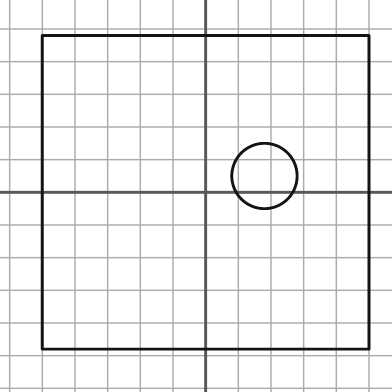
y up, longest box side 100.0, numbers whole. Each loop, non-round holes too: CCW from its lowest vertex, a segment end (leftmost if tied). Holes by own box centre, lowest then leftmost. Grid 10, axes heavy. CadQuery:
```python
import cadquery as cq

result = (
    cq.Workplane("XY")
    .moveTo(-50.0, -48.0)
    .lineTo(50.0, -48.0)
    .lineTo(50.0, 48.0)
    .lineTo(-50.0, 48.0)
    .close()
    .moveTo(18.0, 5.0)
    .circle(10.0)
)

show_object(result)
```